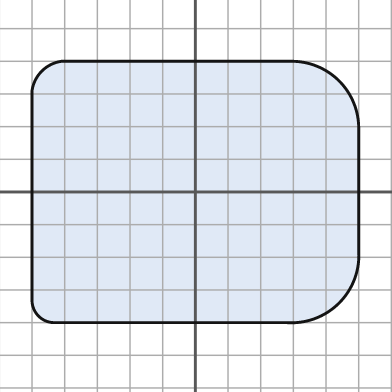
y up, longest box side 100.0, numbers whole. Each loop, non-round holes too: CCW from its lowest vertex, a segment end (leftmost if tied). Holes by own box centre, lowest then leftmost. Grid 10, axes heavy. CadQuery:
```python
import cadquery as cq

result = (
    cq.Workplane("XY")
    .moveTo(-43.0, -40.0)
    .lineTo(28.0, -40.0)
    .threePointArc((44.0, -34.0), (50.0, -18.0))
    .lineTo(50.0, 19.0)
    .threePointArc((44.0, 34.0), (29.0, 40.0))
    .lineTo(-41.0, 40.0)
    .threePointArc((-47.0, 37.0), (-50.0, 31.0))
    .lineTo(-50.0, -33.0)
    .threePointArc((-48.0, -38.0), (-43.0, -40.0))
    .close()
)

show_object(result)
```